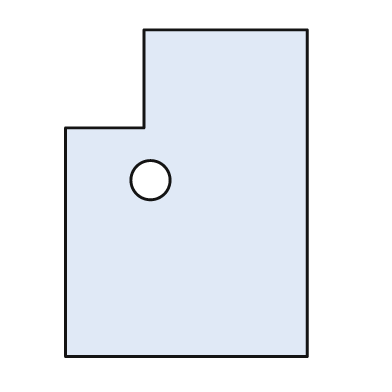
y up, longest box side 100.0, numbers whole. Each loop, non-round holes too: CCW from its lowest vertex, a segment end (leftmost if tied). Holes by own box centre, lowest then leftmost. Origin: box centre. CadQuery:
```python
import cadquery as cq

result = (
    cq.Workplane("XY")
    .moveTo(-37.0, -50.0)
    .lineTo(37.0, -50.0)
    .lineTo(37.0, 50.0)
    .lineTo(-13.0, 50.0)
    .lineTo(-13.0, 20.0)
    .lineTo(-37.0, 20.0)
    .close()
    .moveTo(-11.0, 4.0)
    .circle(6.0)
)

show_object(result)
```